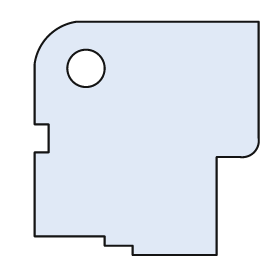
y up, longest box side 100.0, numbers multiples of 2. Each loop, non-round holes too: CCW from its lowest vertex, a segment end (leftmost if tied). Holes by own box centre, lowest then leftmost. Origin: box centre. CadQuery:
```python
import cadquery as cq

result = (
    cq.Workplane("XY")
    .moveTo(-6.0, -50.0)
    .lineTo(30.0, -50.0)
    .lineTo(30.0, -8.0)
    .lineTo(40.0, -8.0)
    .threePointArc((46.0, -6.0), (48.0, 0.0))
    .lineTo(48.0, 50.0)
    .lineTo(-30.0, 50.0)
    .threePointArc((-42.0, 44.0), (-48.0, 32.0))
    .lineTo(-48.0, 6.0)
    .lineTo(-42.0, 6.0)
    .lineTo(-42.0, -6.0)
    .lineTo(-48.0, -6.0)
    .lineTo(-48.0, -42.0)
    .lineTo(-18.0, -42.0)
    .lineTo(-18.0, -46.0)
    .lineTo(-6.0, -46.0)
    .close()
    .moveTo(-26.0, 30.0)
    .circle(8.0)
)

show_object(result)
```